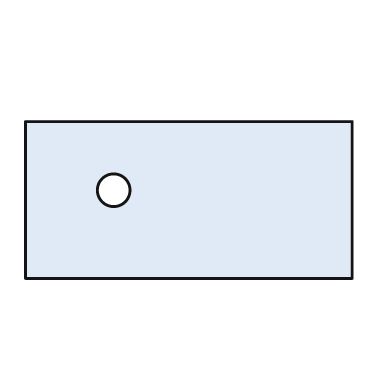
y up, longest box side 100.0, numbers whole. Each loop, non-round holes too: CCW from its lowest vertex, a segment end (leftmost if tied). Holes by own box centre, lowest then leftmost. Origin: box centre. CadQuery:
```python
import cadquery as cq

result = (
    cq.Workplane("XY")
    .moveTo(-50.0, -24.0)
    .lineTo(50.0, -24.0)
    .lineTo(50.0, 24.0)
    .lineTo(-50.0, 24.0)
    .close()
    .moveTo(-23.0, 3.0)
    .circle(5.0)
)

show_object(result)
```